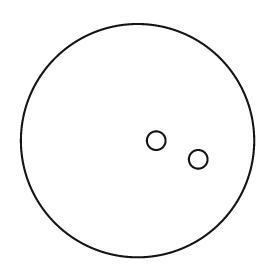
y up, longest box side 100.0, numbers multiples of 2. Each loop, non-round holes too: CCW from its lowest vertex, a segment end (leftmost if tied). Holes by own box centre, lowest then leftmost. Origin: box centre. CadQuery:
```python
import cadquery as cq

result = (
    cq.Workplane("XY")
    .moveTo(0.0, 0.0)
    .circle(50.0)
    .moveTo(26.0, -8.0)
    .circle(4.0)
    .moveTo(8.0, 0.0)
    .circle(4.0)
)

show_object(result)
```